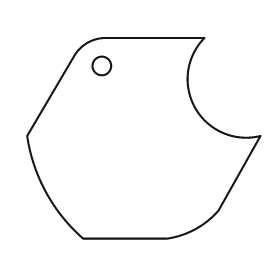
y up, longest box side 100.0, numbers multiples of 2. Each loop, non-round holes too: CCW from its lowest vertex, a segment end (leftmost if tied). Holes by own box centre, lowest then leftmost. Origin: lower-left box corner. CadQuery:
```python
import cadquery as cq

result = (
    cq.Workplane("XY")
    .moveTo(24.0, 0.0)
    .lineTo(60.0, 0.0)
    .threePointArc((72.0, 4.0), (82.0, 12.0))
    .lineTo(100.0, 44.0)
    .threePointArc((72.0, 56.0), (76.0, 86.0))
    .lineTo(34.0, 86.0)
    .threePointArc((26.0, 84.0), (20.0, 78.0))
    .lineTo(0.0, 44.0)
    .threePointArc((8.0, 20.0), (24.0, 0.0))
    .close()
    .moveTo(32.0, 74.0)
    .circle(4.0)
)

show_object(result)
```